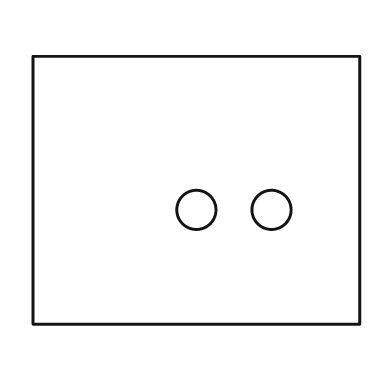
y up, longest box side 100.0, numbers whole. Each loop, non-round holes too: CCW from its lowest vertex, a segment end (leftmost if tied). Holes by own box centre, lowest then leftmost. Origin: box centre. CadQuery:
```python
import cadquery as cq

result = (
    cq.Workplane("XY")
    .moveTo(-50.0, -41.0)
    .lineTo(50.0, -41.0)
    .lineTo(50.0, 41.0)
    .lineTo(-50.0, 41.0)
    .close()
    .moveTo(0.0, -6.0)
    .circle(6.0)
    .moveTo(23.0, -6.0)
    .circle(6.0)
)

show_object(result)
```